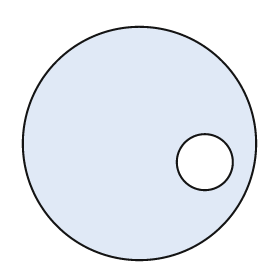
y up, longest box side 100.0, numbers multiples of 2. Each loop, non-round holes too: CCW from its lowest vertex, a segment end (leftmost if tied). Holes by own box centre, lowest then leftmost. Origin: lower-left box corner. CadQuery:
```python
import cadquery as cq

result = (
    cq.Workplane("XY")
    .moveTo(50.0, 50.0)
    .circle(50.0)
    .moveTo(78.0, 42.0)
    .circle(12.0)
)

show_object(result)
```